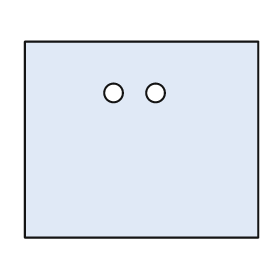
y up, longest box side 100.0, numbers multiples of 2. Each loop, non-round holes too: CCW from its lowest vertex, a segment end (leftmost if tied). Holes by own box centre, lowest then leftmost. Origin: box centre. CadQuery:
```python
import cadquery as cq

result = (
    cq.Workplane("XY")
    .moveTo(-50.0, -42.0)
    .lineTo(50.0, -42.0)
    .lineTo(50.0, 42.0)
    .lineTo(-50.0, 42.0)
    .close()
    .moveTo(-12.0, 20.0)
    .circle(4.0)
    .moveTo(6.0, 20.0)
    .circle(4.0)
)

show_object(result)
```